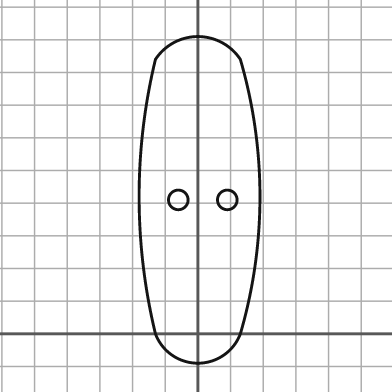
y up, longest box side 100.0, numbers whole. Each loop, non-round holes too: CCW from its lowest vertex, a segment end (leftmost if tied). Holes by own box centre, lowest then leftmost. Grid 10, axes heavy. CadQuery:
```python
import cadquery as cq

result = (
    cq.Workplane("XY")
    .moveTo(-13.0, 0.0)
    .threePointArc((0.0, -9.0), (13.0, 0.0))
    .threePointArc((19.0, 42.0), (13.0, 84.0))
    .threePointArc((0.0, 91.0), (-13.0, 84.0))
    .threePointArc((-18.0, 42.0), (-13.0, 0.0))
    .close()
    .moveTo(-6.0, 41.0)
    .circle(3.0)
    .moveTo(9.0, 41.0)
    .circle(3.0)
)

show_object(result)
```